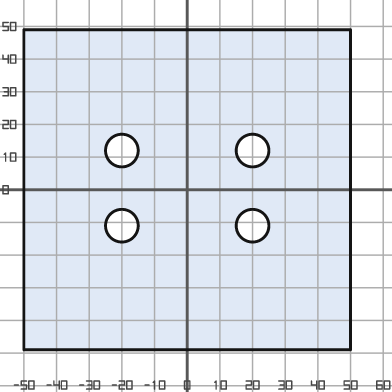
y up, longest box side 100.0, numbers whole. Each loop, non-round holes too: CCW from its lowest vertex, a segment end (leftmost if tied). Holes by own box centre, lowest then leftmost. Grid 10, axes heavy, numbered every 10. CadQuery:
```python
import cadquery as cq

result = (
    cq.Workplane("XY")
    .moveTo(-50.0, -49.0)
    .lineTo(50.0, -49.0)
    .lineTo(50.0, 49.0)
    .lineTo(-50.0, 49.0)
    .close()
    .moveTo(-20.0, -11.0)
    .circle(5.0)
    .moveTo(20.0, -11.0)
    .circle(5.0)
    .moveTo(-20.0, 12.0)
    .circle(5.0)
    .moveTo(20.0, 12.0)
    .circle(5.0)
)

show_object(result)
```